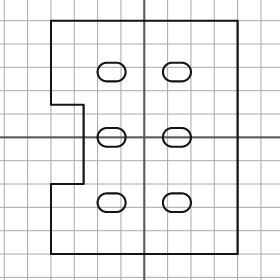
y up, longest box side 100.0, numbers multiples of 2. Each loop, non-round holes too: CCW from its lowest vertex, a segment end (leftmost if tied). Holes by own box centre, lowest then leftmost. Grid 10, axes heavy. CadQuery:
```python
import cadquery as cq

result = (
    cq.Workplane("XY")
    .moveTo(-40.0, -50.0)
    .lineTo(40.0, -50.0)
    .lineTo(40.0, 50.0)
    .lineTo(-40.0, 50.0)
    .lineTo(-40.0, 14.0)
    .lineTo(-26.0, 14.0)
    .lineTo(-26.0, -20.0)
    .lineTo(-40.0, -20.0)
    .close()
    .moveTo(-16.0, -32.0)
    .lineTo(-12.0, -32.0)
    .threePointArc((-8.0, -28.0), (-12.0, -24.0))
    .lineTo(-16.0, -24.0)
    .threePointArc((-20.0, -28.0), (-16.0, -32.0))
    .close()
    .moveTo(12.0, -32.0)
    .lineTo(16.0, -32.0)
    .threePointArc((20.0, -28.0), (16.0, -24.0))
    .lineTo(12.0, -24.0)
    .threePointArc((8.0, -28.0), (12.0, -32.0))
    .close()
    .moveTo(-16.0, -4.0)
    .lineTo(-12.0, -4.0)
    .threePointArc((-8.0, 0.0), (-12.0, 4.0))
    .lineTo(-16.0, 4.0)
    .threePointArc((-20.0, 0.0), (-16.0, -4.0))
    .close()
    .moveTo(12.0, -4.0)
    .lineTo(16.0, -4.0)
    .threePointArc((20.0, 0.0), (16.0, 4.0))
    .lineTo(12.0, 4.0)
    .threePointArc((8.0, 0.0), (12.0, -4.0))
    .close()
    .moveTo(-16.0, 24.0)
    .lineTo(-12.0, 24.0)
    .threePointArc((-8.0, 28.0), (-12.0, 32.0))
    .lineTo(-16.0, 32.0)
    .threePointArc((-20.0, 28.0), (-16.0, 24.0))
    .close()
    .moveTo(12.0, 24.0)
    .lineTo(16.0, 24.0)
    .threePointArc((20.0, 28.0), (16.0, 32.0))
    .lineTo(12.0, 32.0)
    .threePointArc((8.0, 28.0), (12.0, 24.0))
    .close()
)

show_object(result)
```